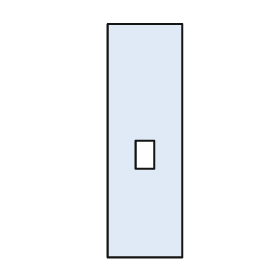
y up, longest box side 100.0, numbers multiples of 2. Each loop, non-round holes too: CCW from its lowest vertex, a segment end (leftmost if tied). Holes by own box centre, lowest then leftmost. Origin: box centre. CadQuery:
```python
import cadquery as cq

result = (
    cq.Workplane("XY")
    .moveTo(-16.0, -50.0)
    .lineTo(16.0, -50.0)
    .lineTo(16.0, 50.0)
    .lineTo(-16.0, 50.0)
    .close()
    .moveTo(-4.0, -12.0)
    .lineTo(4.0, -12.0)
    .lineTo(4.0, 0.0)
    .lineTo(-4.0, 0.0)
    .close()
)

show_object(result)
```